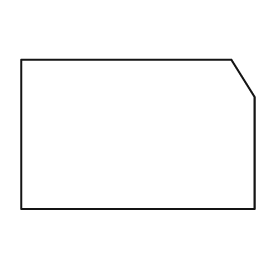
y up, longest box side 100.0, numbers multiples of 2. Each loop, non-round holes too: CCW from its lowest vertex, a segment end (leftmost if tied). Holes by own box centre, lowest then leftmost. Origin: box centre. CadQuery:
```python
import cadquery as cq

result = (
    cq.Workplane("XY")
    .moveTo(-50.0, -32.0)
    .lineTo(50.0, -32.0)
    .lineTo(50.0, 16.0)
    .lineTo(40.0, 32.0)
    .lineTo(-50.0, 32.0)
    .close()
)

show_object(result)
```